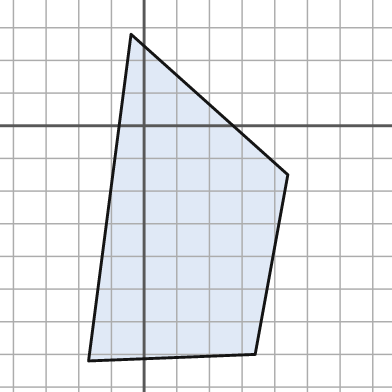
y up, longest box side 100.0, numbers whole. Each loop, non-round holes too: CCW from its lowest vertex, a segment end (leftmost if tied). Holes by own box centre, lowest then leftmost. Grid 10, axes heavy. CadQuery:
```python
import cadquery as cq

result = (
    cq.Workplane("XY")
    .moveTo(-17.0, -72.0)
    .lineTo(34.0, -70.0)
    .lineTo(44.0, -15.0)
    .lineTo(-4.0, 28.0)
    .close()
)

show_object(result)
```